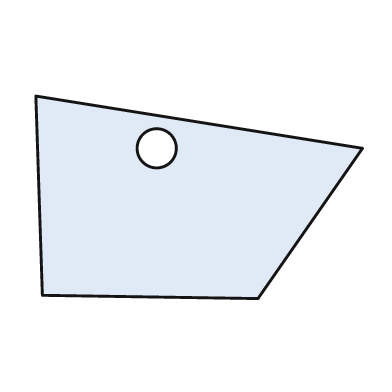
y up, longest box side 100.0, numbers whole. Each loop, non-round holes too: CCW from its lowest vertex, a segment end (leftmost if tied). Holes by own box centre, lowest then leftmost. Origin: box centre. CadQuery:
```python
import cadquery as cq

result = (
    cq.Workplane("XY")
    .moveTo(18.0, -31.0)
    .lineTo(50.0, 15.0)
    .lineTo(-50.0, 31.0)
    .lineTo(-48.0, -30.0)
    .close()
    .moveTo(-13.0, 15.0)
    .circle(6.0)
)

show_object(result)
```